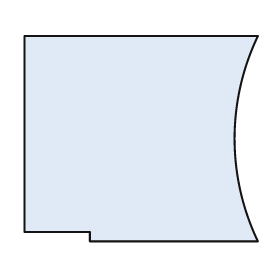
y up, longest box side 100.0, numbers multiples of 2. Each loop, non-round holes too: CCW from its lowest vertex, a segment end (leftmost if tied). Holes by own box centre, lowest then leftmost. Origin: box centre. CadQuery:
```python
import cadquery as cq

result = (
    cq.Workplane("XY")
    .moveTo(-22.0, -44.0)
    .lineTo(50.0, -44.0)
    .threePointArc((40.0, 0.0), (50.0, 44.0))
    .lineTo(-50.0, 44.0)
    .lineTo(-50.0, -40.0)
    .lineTo(-22.0, -40.0)
    .close()
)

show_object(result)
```